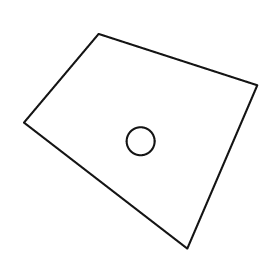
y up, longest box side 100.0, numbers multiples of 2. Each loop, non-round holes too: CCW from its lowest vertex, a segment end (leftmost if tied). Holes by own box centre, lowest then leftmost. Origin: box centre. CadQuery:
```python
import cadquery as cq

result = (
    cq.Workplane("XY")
    .moveTo(20.0, -46.0)
    .lineTo(50.0, 24.0)
    .lineTo(-18.0, 46.0)
    .lineTo(-50.0, 8.0)
    .close()
    .moveTo(0.0, 0.0)
    .circle(6.0)
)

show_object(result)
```